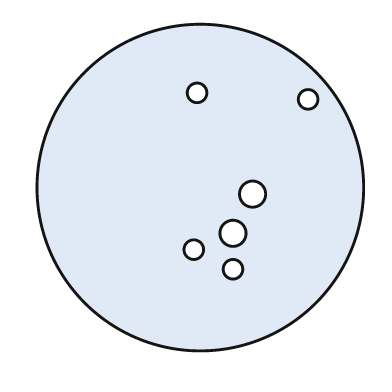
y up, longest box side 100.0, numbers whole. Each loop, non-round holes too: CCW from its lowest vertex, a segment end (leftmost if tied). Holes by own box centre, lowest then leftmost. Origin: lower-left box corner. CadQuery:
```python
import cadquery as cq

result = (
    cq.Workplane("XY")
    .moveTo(50.0, 50.0)
    .circle(50.0)
    .moveTo(60.0, 25.0)
    .circle(3.0)
    .moveTo(48.0, 31.0)
    .circle(3.0)
    .moveTo(60.0, 36.0)
    .circle(4.0)
    .moveTo(66.0, 48.0)
    .circle(4.0)
    .moveTo(83.0, 77.0)
    .circle(3.0)
    .moveTo(49.0, 79.0)
    .circle(3.0)
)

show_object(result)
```